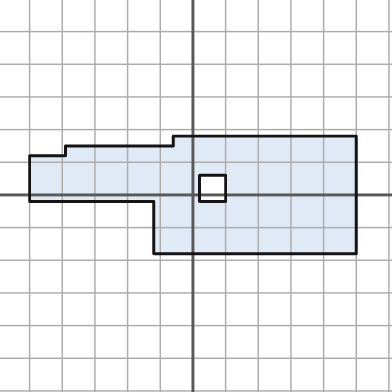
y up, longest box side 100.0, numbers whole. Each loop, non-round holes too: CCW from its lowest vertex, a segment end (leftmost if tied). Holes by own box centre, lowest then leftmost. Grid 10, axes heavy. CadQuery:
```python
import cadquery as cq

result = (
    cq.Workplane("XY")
    .moveTo(-12.0, -18.0)
    .lineTo(50.0, -18.0)
    .lineTo(50.0, 18.0)
    .lineTo(-6.0, 18.0)
    .lineTo(-6.0, 15.0)
    .lineTo(-39.0, 15.0)
    .lineTo(-39.0, 12.0)
    .lineTo(-50.0, 12.0)
    .lineTo(-50.0, -2.0)
    .lineTo(-12.0, -2.0)
    .close()
    .moveTo(2.0, -2.0)
    .lineTo(10.0, -2.0)
    .lineTo(10.0, 6.0)
    .lineTo(2.0, 6.0)
    .close()
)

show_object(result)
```